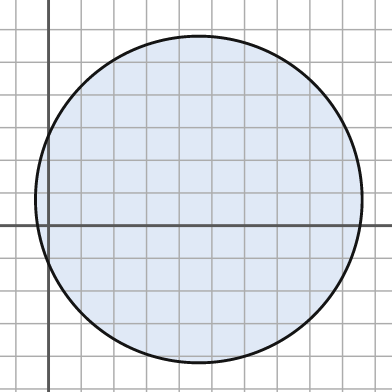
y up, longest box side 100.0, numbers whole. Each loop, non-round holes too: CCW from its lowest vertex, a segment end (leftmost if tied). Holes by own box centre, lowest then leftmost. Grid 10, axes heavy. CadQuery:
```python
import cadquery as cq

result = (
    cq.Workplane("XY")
    .moveTo(46.0, 8.0)
    .circle(50.0)
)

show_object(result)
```